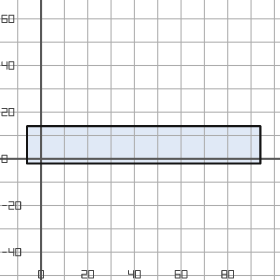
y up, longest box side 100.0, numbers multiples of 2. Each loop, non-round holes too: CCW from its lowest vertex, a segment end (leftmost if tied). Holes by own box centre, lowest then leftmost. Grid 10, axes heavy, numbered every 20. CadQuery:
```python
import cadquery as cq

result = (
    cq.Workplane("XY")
    .moveTo(-6.0, -2.0)
    .lineTo(94.0, -2.0)
    .lineTo(94.0, 14.0)
    .lineTo(-6.0, 14.0)
    .close()
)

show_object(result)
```